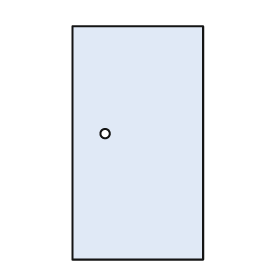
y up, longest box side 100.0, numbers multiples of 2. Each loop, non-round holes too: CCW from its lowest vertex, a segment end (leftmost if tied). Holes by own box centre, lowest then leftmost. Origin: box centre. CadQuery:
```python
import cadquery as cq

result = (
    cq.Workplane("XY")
    .moveTo(-28.0, -50.0)
    .lineTo(28.0, -50.0)
    .lineTo(28.0, 50.0)
    .lineTo(-28.0, 50.0)
    .close()
    .moveTo(-14.0, 4.0)
    .circle(2.0)
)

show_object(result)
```